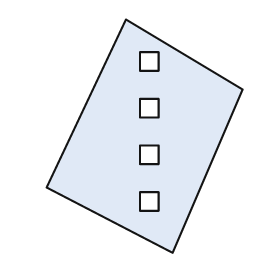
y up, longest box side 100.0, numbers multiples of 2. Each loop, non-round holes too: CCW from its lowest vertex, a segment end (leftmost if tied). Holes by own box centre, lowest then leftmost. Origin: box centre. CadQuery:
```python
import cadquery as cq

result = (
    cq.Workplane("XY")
    .moveTo(12.0, -50.0)
    .lineTo(42.0, 20.0)
    .lineTo(-8.0, 50.0)
    .lineTo(-42.0, -22.0)
    .close()
    .moveTo(-2.0, -32.0)
    .lineTo(6.0, -32.0)
    .lineTo(6.0, -24.0)
    .lineTo(-2.0, -24.0)
    .close()
    .moveTo(-2.0, -12.0)
    .lineTo(6.0, -12.0)
    .lineTo(6.0, -4.0)
    .lineTo(-2.0, -4.0)
    .close()
    .moveTo(-2.0, 8.0)
    .lineTo(6.0, 8.0)
    .lineTo(6.0, 16.0)
    .lineTo(-2.0, 16.0)
    .close()
    .moveTo(-2.0, 28.0)
    .lineTo(6.0, 28.0)
    .lineTo(6.0, 36.0)
    .lineTo(-2.0, 36.0)
    .close()
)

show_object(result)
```